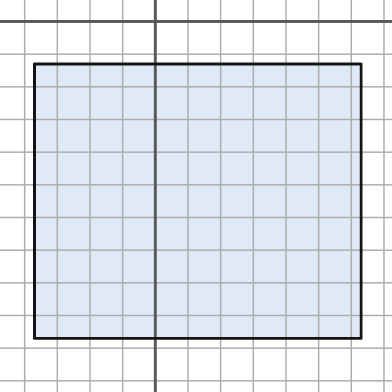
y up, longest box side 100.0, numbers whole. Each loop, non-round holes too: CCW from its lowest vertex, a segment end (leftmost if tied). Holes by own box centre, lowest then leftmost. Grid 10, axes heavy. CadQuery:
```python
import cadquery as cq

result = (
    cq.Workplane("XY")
    .moveTo(-37.0, -97.0)
    .lineTo(63.0, -97.0)
    .lineTo(63.0, -13.0)
    .lineTo(-37.0, -13.0)
    .close()
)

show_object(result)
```